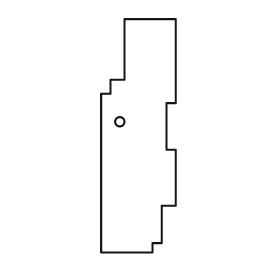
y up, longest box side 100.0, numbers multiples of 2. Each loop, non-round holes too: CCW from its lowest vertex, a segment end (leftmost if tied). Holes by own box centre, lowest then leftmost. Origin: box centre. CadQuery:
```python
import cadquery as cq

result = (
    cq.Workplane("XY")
    .moveTo(-16.0, -50.0)
    .lineTo(6.0, -50.0)
    .lineTo(6.0, -46.0)
    .lineTo(10.0, -46.0)
    .lineTo(10.0, -30.0)
    .lineTo(16.0, -30.0)
    .lineTo(16.0, -6.0)
    .lineTo(12.0, -6.0)
    .lineTo(12.0, 14.0)
    .lineTo(16.0, 14.0)
    .lineTo(16.0, 50.0)
    .lineTo(-6.0, 50.0)
    .lineTo(-6.0, 24.0)
    .lineTo(-12.0, 24.0)
    .lineTo(-12.0, 18.0)
    .lineTo(-16.0, 18.0)
    .close()
    .moveTo(-8.0, 6.0)
    .circle(2.0)
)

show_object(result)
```